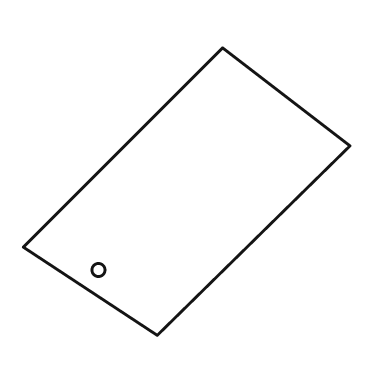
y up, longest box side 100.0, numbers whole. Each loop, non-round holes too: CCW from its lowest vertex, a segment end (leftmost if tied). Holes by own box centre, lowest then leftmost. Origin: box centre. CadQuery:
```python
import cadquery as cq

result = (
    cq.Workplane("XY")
    .moveTo(-9.0, -44.0)
    .lineTo(50.0, 14.0)
    .lineTo(11.0, 44.0)
    .lineTo(-50.0, -17.0)
    .close()
    .moveTo(-27.0, -24.0)
    .circle(2.0)
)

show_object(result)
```